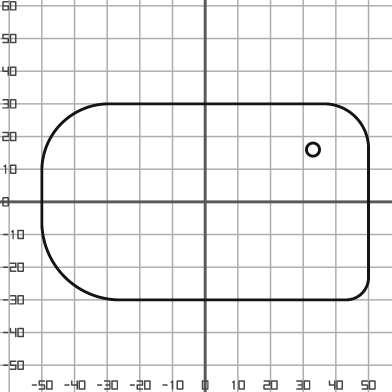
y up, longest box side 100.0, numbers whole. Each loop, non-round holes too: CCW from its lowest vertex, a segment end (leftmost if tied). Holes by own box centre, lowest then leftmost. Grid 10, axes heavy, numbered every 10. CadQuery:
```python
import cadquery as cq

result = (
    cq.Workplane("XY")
    .moveTo(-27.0, -30.0)
    .lineTo(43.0, -30.0)
    .threePointArc((48.0, -28.0), (50.0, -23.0))
    .lineTo(50.0, 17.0)
    .threePointArc((46.0, 26.0), (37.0, 30.0))
    .lineTo(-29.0, 30.0)
    .threePointArc((-44.0, 24.0), (-50.0, 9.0))
    .lineTo(-50.0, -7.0)
    .threePointArc((-43.0, -23.0), (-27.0, -30.0))
    .close()
    .moveTo(33.0, 16.0)
    .circle(2.0)
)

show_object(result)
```